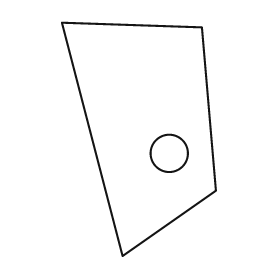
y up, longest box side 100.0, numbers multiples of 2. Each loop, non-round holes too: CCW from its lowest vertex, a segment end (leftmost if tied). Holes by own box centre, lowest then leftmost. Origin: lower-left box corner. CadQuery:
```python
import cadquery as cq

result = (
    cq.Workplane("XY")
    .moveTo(26.0, 0.0)
    .lineTo(66.0, 28.0)
    .lineTo(60.0, 98.0)
    .lineTo(0.0, 100.0)
    .close()
    .moveTo(46.0, 44.0)
    .circle(8.0)
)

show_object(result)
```